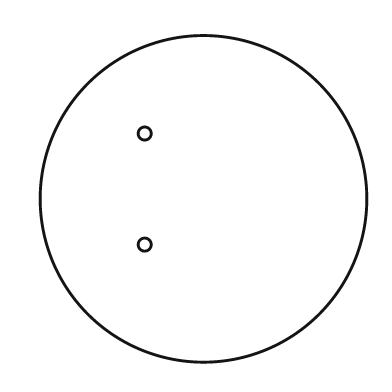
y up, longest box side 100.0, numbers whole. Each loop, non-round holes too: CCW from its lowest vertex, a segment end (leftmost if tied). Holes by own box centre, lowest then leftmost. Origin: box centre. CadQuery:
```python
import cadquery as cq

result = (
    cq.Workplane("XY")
    .moveTo(0.0, 0.0)
    .circle(50.0)
    .moveTo(-18.0, -14.0)
    .circle(2.0)
    .moveTo(-18.0, 20.0)
    .circle(2.0)
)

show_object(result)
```